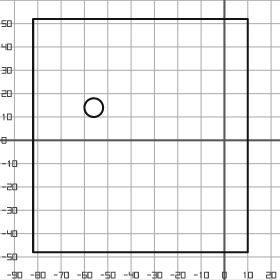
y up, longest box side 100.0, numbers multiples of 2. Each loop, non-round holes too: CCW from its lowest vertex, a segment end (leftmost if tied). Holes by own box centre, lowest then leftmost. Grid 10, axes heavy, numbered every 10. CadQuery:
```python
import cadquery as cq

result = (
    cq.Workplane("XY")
    .moveTo(-82.0, -48.0)
    .lineTo(10.0, -48.0)
    .lineTo(10.0, 52.0)
    .lineTo(-82.0, 52.0)
    .close()
    .moveTo(-56.0, 14.0)
    .circle(4.0)
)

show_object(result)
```